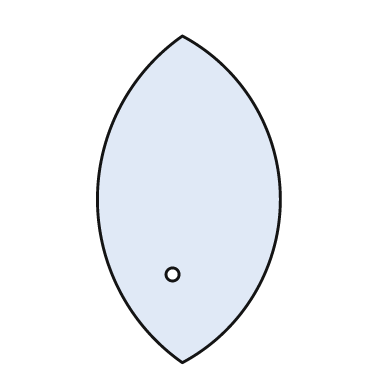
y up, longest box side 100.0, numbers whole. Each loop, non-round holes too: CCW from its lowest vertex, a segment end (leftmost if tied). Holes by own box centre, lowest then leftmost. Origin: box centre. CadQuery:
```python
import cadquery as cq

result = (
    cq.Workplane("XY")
    .moveTo(-2.0, -50.0)
    .threePointArc((28.0, 0.0), (-2.0, 50.0))
    .threePointArc((-28.0, 0.0), (-2.0, -50.0))
    .close()
    .moveTo(-5.0, -23.0)
    .circle(2.0)
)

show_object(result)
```